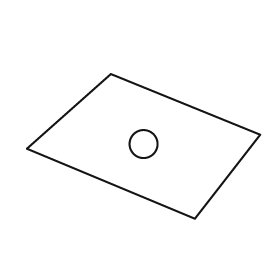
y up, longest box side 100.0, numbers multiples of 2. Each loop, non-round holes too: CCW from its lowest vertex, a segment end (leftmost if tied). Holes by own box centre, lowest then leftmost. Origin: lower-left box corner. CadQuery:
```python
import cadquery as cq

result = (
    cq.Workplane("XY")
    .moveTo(72.0, 0.0)
    .lineTo(100.0, 36.0)
    .lineTo(36.0, 62.0)
    .lineTo(0.0, 30.0)
    .close()
    .moveTo(50.0, 32.0)
    .circle(6.0)
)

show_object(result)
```